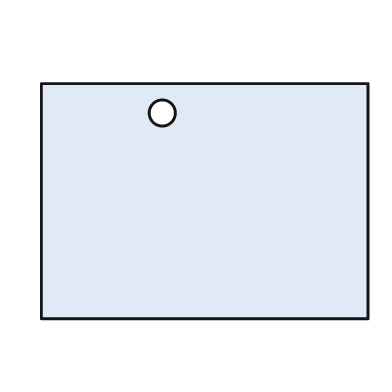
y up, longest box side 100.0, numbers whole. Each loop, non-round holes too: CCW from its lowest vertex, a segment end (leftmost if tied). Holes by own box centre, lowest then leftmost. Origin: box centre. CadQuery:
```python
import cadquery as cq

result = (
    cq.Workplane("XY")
    .moveTo(-50.0, -36.0)
    .lineTo(50.0, -36.0)
    .lineTo(50.0, 36.0)
    .lineTo(-50.0, 36.0)
    .close()
    .moveTo(-13.0, 27.0)
    .circle(4.0)
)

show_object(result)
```